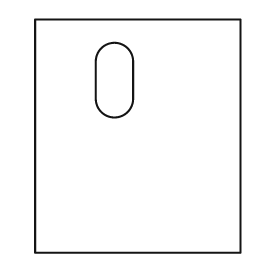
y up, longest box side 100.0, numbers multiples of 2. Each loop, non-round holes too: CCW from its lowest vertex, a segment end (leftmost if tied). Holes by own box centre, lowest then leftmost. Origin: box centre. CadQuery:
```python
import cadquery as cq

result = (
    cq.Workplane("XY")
    .moveTo(-44.0, -50.0)
    .lineTo(44.0, -50.0)
    .lineTo(44.0, 50.0)
    .lineTo(-44.0, 50.0)
    .close()
    .moveTo(-18.0, 16.0)
    .threePointArc((-10.0, 8.0), (-2.0, 16.0))
    .lineTo(-2.0, 32.0)
    .threePointArc((-10.0, 40.0), (-18.0, 32.0))
    .close()
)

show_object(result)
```